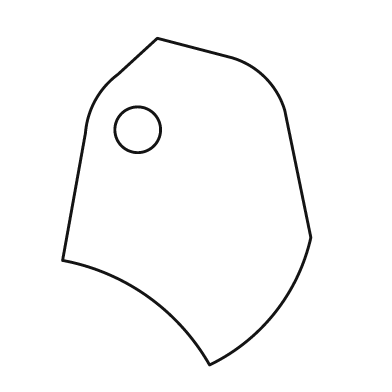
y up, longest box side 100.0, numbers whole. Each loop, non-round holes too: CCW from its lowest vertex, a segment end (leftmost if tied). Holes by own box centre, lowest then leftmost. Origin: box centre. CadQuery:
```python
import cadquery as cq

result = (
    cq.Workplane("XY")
    .moveTo(7.0, -50.0)
    .threePointArc((27.0, -34.0), (38.0, -11.0))
    .lineTo(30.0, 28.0)
    .threePointArc((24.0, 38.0), (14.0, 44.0))
    .lineTo(-9.0, 50.0)
    .lineTo(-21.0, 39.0)
    .threePointArc((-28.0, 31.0), (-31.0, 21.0))
    .lineTo(-38.0, -18.0)
    .threePointArc((-12.0, -29.0), (7.0, -50.0))
    .close()
    .moveTo(-15.0, 22.0)
    .circle(7.0)
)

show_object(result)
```